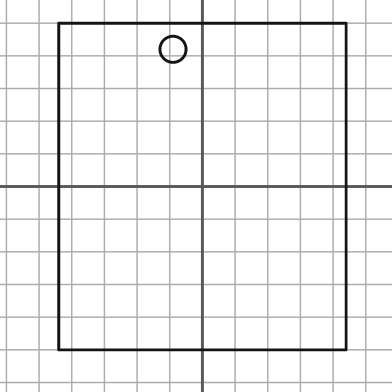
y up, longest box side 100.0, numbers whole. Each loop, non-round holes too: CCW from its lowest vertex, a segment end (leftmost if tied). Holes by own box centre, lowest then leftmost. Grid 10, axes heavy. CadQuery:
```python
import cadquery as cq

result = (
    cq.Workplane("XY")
    .moveTo(-44.0, -50.0)
    .lineTo(44.0, -50.0)
    .lineTo(44.0, 50.0)
    .lineTo(-44.0, 50.0)
    .close()
    .moveTo(-9.0, 42.0)
    .circle(4.0)
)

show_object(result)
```